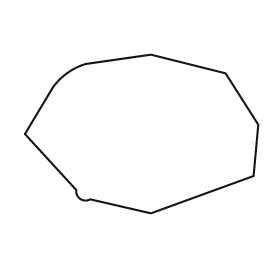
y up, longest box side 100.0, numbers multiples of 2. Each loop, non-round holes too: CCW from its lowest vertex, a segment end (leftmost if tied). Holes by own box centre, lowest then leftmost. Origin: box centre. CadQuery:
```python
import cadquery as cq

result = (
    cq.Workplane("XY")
    .moveTo(4.0, -34.0)
    .lineTo(48.0, -18.0)
    .lineTo(50.0, 4.0)
    .lineTo(36.0, 26.0)
    .lineTo(4.0, 34.0)
    .lineTo(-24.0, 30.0)
    .threePointArc((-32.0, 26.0), (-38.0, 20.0))
    .lineTo(-50.0, 0.0)
    .lineTo(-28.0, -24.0)
    .threePointArc((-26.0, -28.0), (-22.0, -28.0))
    .close()
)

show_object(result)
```